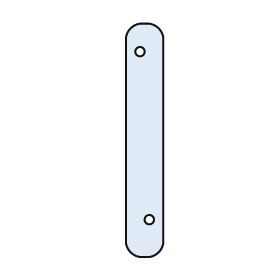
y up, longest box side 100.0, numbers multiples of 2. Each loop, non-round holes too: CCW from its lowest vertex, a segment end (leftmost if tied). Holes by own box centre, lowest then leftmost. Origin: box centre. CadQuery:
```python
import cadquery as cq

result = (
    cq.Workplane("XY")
    .moveTo(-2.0, -50.0)
    .lineTo(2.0, -50.0)
    .threePointArc((6.0, -48.0), (8.0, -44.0))
    .lineTo(8.0, 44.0)
    .threePointArc((6.0, 48.0), (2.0, 50.0))
    .lineTo(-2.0, 50.0)
    .threePointArc((-6.0, 48.0), (-8.0, 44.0))
    .lineTo(-8.0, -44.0)
    .threePointArc((-6.0, -48.0), (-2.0, -50.0))
    .close()
    .moveTo(2.0, -34.0)
    .circle(2.0)
    .moveTo(-2.0, 38.0)
    .circle(2.0)
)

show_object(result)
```